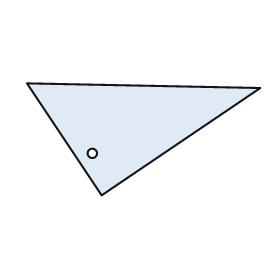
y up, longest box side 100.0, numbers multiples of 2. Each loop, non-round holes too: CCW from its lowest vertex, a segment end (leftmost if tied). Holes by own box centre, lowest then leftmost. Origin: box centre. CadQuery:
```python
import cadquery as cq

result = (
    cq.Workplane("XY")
    .moveTo(-18.0, -24.0)
    .lineTo(50.0, 22.0)
    .lineTo(-50.0, 24.0)
    .close()
    .moveTo(-22.0, -6.0)
    .circle(2.0)
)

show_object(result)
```